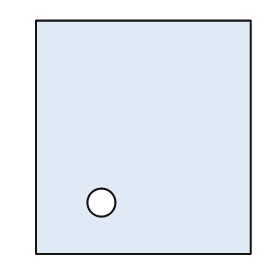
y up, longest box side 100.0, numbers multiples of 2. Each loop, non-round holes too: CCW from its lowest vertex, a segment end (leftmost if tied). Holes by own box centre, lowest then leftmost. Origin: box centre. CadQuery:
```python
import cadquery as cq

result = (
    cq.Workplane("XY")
    .moveTo(-46.0, -50.0)
    .lineTo(46.0, -50.0)
    .lineTo(46.0, 50.0)
    .lineTo(-46.0, 50.0)
    .close()
    .moveTo(-18.0, -28.0)
    .circle(6.0)
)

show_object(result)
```